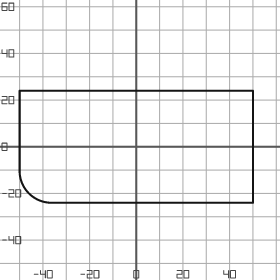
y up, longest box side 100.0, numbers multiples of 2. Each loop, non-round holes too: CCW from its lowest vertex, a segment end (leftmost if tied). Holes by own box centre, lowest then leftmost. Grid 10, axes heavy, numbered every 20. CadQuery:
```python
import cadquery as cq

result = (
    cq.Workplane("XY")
    .moveTo(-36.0, -24.0)
    .lineTo(50.0, -24.0)
    .lineTo(50.0, 24.0)
    .lineTo(-50.0, 24.0)
    .lineTo(-50.0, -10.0)
    .threePointArc((-46.0, -20.0), (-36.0, -24.0))
    .close()
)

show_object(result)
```